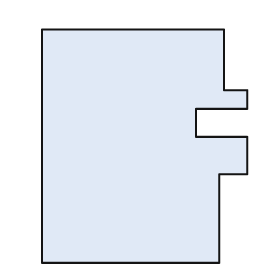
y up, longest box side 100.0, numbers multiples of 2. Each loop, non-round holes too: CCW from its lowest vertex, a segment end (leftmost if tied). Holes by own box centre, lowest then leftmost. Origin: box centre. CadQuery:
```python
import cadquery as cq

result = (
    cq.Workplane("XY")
    .moveTo(-44.0, -50.0)
    .lineTo(32.0, -50.0)
    .lineTo(32.0, -12.0)
    .lineTo(44.0, -12.0)
    .lineTo(44.0, 4.0)
    .lineTo(22.0, 4.0)
    .lineTo(22.0, 16.0)
    .lineTo(44.0, 16.0)
    .lineTo(44.0, 24.0)
    .lineTo(34.0, 24.0)
    .lineTo(34.0, 50.0)
    .lineTo(-44.0, 50.0)
    .close()
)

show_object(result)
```